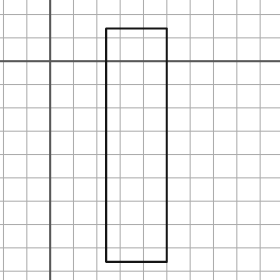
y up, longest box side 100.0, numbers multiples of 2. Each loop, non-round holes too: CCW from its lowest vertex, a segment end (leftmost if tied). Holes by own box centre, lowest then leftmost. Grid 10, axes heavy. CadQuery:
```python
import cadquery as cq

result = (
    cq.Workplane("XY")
    .moveTo(24.0, -86.0)
    .lineTo(50.0, -86.0)
    .lineTo(50.0, 14.0)
    .lineTo(24.0, 14.0)
    .close()
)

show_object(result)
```